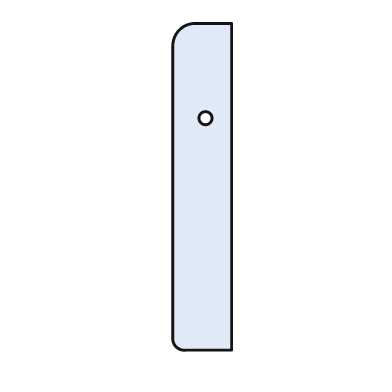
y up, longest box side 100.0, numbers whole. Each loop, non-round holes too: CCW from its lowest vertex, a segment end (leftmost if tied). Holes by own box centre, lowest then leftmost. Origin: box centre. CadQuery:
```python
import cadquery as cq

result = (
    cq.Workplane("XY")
    .moveTo(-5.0, -50.0)
    .lineTo(9.0, -50.0)
    .lineTo(9.0, 50.0)
    .lineTo(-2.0, 50.0)
    .threePointArc((-7.0, 48.0), (-9.0, 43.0))
    .lineTo(-9.0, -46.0)
    .threePointArc((-8.0, -49.0), (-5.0, -50.0))
    .close()
    .moveTo(1.0, 21.0)
    .circle(2.0)
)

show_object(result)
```